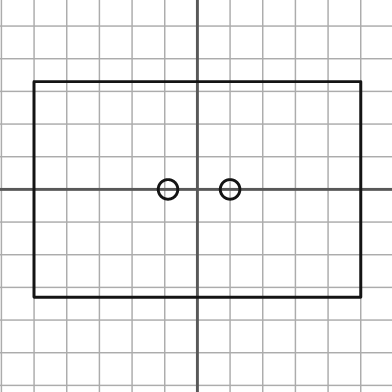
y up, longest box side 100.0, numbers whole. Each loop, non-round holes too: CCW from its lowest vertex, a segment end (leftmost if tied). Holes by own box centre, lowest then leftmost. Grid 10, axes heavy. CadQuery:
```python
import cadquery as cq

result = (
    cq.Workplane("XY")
    .moveTo(-50.0, -33.0)
    .lineTo(50.0, -33.0)
    .lineTo(50.0, 33.0)
    .lineTo(-50.0, 33.0)
    .close()
    .moveTo(-9.0, 0.0)
    .circle(3.0)
    .moveTo(10.0, 0.0)
    .circle(3.0)
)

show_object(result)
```